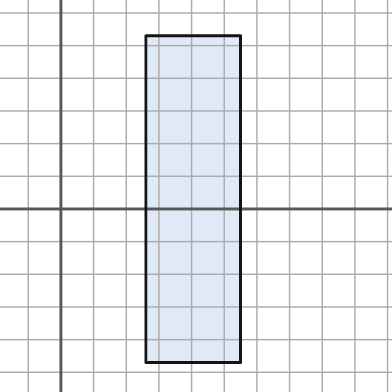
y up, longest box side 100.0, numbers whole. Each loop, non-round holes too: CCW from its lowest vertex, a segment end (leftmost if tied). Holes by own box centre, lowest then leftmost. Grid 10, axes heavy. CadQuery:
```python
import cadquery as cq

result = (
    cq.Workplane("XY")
    .moveTo(26.0, -47.0)
    .lineTo(55.0, -47.0)
    .lineTo(55.0, 53.0)
    .lineTo(26.0, 53.0)
    .close()
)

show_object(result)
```